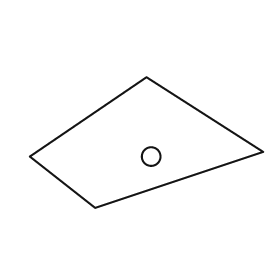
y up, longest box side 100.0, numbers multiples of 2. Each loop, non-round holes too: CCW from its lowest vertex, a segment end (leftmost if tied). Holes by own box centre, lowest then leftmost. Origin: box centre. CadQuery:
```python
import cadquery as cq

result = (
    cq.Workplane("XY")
    .moveTo(-22.0, -28.0)
    .lineTo(50.0, -4.0)
    .lineTo(0.0, 28.0)
    .lineTo(-50.0, -6.0)
    .close()
    .moveTo(2.0, -6.0)
    .circle(4.0)
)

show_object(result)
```